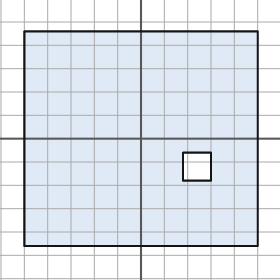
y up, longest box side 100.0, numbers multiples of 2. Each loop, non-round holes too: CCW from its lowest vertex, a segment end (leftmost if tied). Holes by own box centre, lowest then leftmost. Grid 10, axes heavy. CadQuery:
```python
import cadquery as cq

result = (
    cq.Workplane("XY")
    .moveTo(-50.0, -46.0)
    .lineTo(50.0, -46.0)
    .lineTo(50.0, 46.0)
    .lineTo(-50.0, 46.0)
    .close()
    .moveTo(18.0, -18.0)
    .lineTo(30.0, -18.0)
    .lineTo(30.0, -6.0)
    .lineTo(18.0, -6.0)
    .close()
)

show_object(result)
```